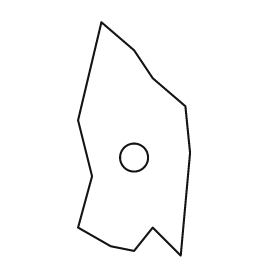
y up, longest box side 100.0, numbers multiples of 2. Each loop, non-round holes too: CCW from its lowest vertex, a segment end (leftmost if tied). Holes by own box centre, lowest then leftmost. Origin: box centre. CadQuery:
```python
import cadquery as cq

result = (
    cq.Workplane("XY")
    .moveTo(20.0, -50.0)
    .lineTo(24.0, -6.0)
    .lineTo(22.0, 14.0)
    .lineTo(8.0, 26.0)
    .lineTo(0.0, 38.0)
    .lineTo(-14.0, 50.0)
    .lineTo(-24.0, 8.0)
    .lineTo(-18.0, -16.0)
    .lineTo(-24.0, -38.0)
    .lineTo(-10.0, -46.0)
    .lineTo(0.0, -48.0)
    .lineTo(8.0, -38.0)
    .close()
    .moveTo(0.0, -8.0)
    .circle(6.0)
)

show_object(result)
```